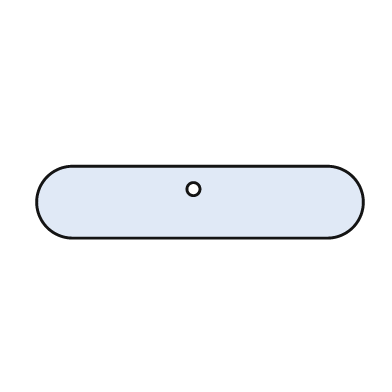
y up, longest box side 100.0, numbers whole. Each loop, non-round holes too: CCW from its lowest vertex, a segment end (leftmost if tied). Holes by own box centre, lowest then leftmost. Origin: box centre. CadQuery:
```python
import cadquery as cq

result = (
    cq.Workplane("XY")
    .moveTo(-39.0, -11.0)
    .lineTo(39.0, -11.0)
    .threePointArc((50.0, 0.0), (39.0, 11.0))
    .lineTo(-39.0, 11.0)
    .threePointArc((-50.0, 0.0), (-39.0, -11.0))
    .close()
    .moveTo(-2.0, 4.0)
    .circle(2.0)
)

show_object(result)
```